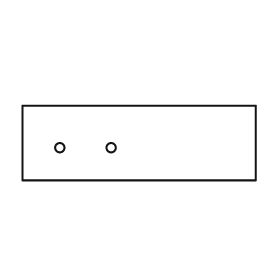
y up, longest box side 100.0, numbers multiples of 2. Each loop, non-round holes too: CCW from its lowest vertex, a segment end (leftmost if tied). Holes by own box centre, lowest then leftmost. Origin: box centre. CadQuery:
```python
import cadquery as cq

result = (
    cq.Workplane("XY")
    .moveTo(-50.0, -16.0)
    .lineTo(50.0, -16.0)
    .lineTo(50.0, 16.0)
    .lineTo(-50.0, 16.0)
    .close()
    .moveTo(-34.0, -2.0)
    .circle(2.0)
    .moveTo(-12.0, -2.0)
    .circle(2.0)
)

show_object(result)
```